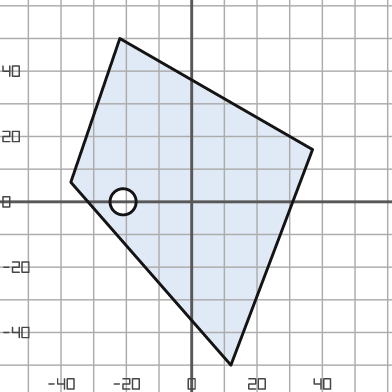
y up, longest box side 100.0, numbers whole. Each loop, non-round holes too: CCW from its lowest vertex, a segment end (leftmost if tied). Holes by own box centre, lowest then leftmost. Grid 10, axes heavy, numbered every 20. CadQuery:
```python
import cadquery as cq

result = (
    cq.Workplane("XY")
    .moveTo(12.0, -50.0)
    .lineTo(37.0, 16.0)
    .lineTo(-22.0, 50.0)
    .lineTo(-37.0, 6.0)
    .close()
    .moveTo(-21.0, 0.0)
    .circle(4.0)
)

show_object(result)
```